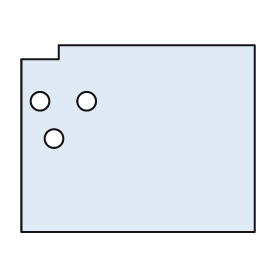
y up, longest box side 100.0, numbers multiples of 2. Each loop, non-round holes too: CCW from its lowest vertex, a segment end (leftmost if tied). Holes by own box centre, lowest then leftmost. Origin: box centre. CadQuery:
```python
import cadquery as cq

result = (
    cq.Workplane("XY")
    .moveTo(-50.0, -40.0)
    .lineTo(50.0, -40.0)
    .lineTo(50.0, 40.0)
    .lineTo(-34.0, 40.0)
    .lineTo(-34.0, 34.0)
    .lineTo(-50.0, 34.0)
    .close()
    .moveTo(-36.0, 0.0)
    .circle(4.0)
    .moveTo(-42.0, 16.0)
    .circle(4.0)
    .moveTo(-22.0, 16.0)
    .circle(4.0)
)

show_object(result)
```